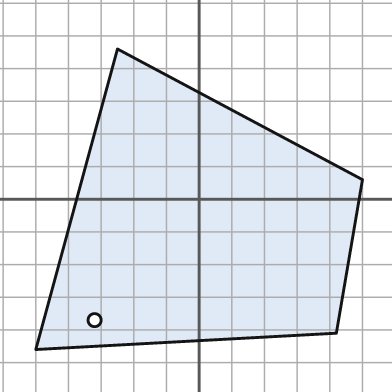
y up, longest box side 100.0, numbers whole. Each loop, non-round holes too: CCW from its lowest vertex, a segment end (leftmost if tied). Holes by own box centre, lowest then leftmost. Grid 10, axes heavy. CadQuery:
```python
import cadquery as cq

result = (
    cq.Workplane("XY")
    .moveTo(-50.0, -46.0)
    .lineTo(42.0, -41.0)
    .lineTo(50.0, 6.0)
    .lineTo(-25.0, 46.0)
    .close()
    .moveTo(-32.0, -37.0)
    .circle(2.0)
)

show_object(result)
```